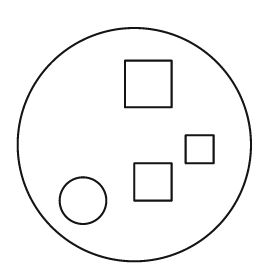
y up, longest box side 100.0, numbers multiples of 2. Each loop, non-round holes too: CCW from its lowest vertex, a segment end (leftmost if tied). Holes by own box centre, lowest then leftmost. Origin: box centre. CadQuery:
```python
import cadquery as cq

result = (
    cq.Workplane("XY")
    .moveTo(0.0, 0.0)
    .circle(50.0)
    .moveTo(-22.0, -24.0)
    .circle(10.0)
    .moveTo(0.0, -24.0)
    .lineTo(16.0, -24.0)
    .lineTo(16.0, -8.0)
    .lineTo(0.0, -8.0)
    .close()
    .moveTo(22.0, -8.0)
    .lineTo(34.0, -8.0)
    .lineTo(34.0, 4.0)
    .lineTo(22.0, 4.0)
    .close()
    .moveTo(-4.0, 16.0)
    .lineTo(16.0, 16.0)
    .lineTo(16.0, 36.0)
    .lineTo(-4.0, 36.0)
    .close()
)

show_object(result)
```